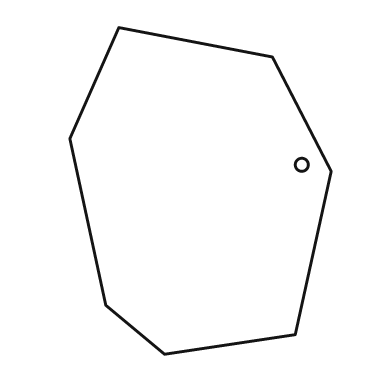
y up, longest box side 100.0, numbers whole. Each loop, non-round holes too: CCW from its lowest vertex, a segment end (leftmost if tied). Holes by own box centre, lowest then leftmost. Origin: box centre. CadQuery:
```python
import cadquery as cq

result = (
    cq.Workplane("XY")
    .moveTo(-11.0, -50.0)
    .lineTo(29.0, -44.0)
    .lineTo(40.0, 6.0)
    .lineTo(22.0, 41.0)
    .lineTo(-25.0, 50.0)
    .lineTo(-40.0, 16.0)
    .lineTo(-29.0, -35.0)
    .close()
    .moveTo(31.0, 8.0)
    .circle(2.0)
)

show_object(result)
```